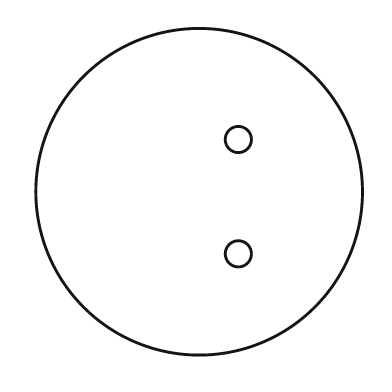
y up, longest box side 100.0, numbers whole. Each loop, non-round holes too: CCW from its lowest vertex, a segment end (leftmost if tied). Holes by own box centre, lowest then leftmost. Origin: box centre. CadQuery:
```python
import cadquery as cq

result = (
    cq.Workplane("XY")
    .moveTo(0.0, 0.0)
    .circle(50.0)
    .moveTo(12.0, -19.0)
    .circle(4.0)
    .moveTo(12.0, 16.0)
    .circle(4.0)
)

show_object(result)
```